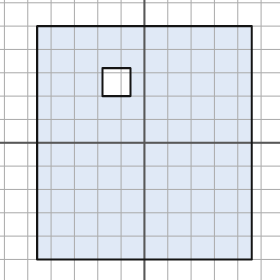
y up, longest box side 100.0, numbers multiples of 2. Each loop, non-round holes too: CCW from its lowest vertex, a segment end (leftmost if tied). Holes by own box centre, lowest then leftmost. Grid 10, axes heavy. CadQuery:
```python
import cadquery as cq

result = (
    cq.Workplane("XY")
    .moveTo(-46.0, -50.0)
    .lineTo(46.0, -50.0)
    .lineTo(46.0, 50.0)
    .lineTo(-46.0, 50.0)
    .close()
    .moveTo(-18.0, 20.0)
    .lineTo(-6.0, 20.0)
    .lineTo(-6.0, 32.0)
    .lineTo(-18.0, 32.0)
    .close()
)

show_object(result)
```